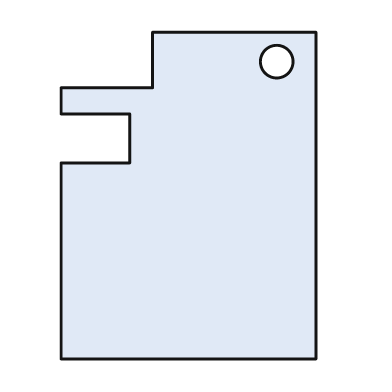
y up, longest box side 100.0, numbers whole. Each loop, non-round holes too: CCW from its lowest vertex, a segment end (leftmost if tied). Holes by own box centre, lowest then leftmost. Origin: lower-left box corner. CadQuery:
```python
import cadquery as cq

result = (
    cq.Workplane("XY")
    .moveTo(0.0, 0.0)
    .lineTo(78.0, 0.0)
    .lineTo(78.0, 100.0)
    .lineTo(28.0, 100.0)
    .lineTo(28.0, 83.0)
    .lineTo(0.0, 83.0)
    .lineTo(0.0, 75.0)
    .lineTo(21.0, 75.0)
    .lineTo(21.0, 60.0)
    .lineTo(0.0, 60.0)
    .close()
    .moveTo(66.0, 91.0)
    .circle(5.0)
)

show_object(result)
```